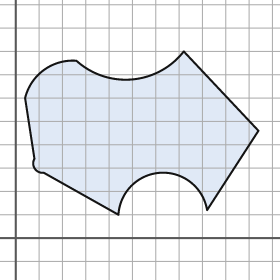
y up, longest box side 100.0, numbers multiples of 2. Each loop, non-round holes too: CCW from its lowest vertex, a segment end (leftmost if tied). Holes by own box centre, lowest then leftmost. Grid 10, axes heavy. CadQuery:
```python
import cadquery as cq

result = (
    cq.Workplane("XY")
    .moveTo(44.0, 10.0)
    .threePointArc((62.0, 28.0), (82.0, 12.0))
    .lineTo(104.0, 46.0)
    .lineTo(72.0, 80.0)
    .threePointArc((50.0, 68.0), (26.0, 76.0))
    .threePointArc((12.0, 72.0), (4.0, 60.0))
    .lineTo(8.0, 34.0)
    .threePointArc((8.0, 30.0), (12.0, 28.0))
    .close()
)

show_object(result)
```